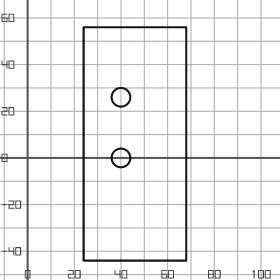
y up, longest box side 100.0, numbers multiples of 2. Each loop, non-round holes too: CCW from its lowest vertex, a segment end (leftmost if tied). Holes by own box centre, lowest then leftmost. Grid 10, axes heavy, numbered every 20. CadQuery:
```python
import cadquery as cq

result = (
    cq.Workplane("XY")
    .moveTo(24.0, -44.0)
    .lineTo(68.0, -44.0)
    .lineTo(68.0, 56.0)
    .lineTo(24.0, 56.0)
    .close()
    .moveTo(40.0, 0.0)
    .circle(4.0)
    .moveTo(40.0, 26.0)
    .circle(4.0)
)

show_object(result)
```